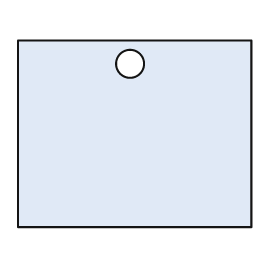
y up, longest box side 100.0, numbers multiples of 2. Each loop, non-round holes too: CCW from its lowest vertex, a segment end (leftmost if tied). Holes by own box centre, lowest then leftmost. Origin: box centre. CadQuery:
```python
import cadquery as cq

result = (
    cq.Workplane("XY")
    .moveTo(-50.0, -40.0)
    .lineTo(50.0, -40.0)
    .lineTo(50.0, 40.0)
    .lineTo(-50.0, 40.0)
    .close()
    .moveTo(-2.0, 30.0)
    .circle(6.0)
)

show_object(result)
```